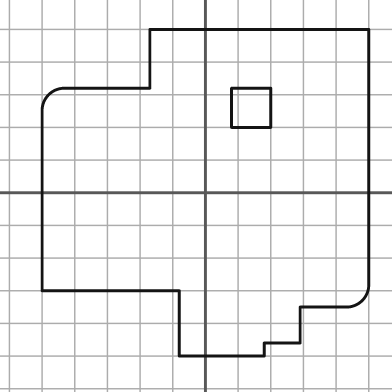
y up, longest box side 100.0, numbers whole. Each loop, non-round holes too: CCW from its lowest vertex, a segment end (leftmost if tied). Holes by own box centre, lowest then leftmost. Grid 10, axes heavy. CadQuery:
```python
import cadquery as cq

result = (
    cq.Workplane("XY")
    .moveTo(-8.0, -50.0)
    .lineTo(18.0, -50.0)
    .lineTo(18.0, -46.0)
    .lineTo(29.0, -46.0)
    .lineTo(29.0, -35.0)
    .lineTo(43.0, -35.0)
    .threePointArc((48.0, -33.0), (50.0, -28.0))
    .lineTo(50.0, 50.0)
    .lineTo(-17.0, 50.0)
    .lineTo(-17.0, 32.0)
    .lineTo(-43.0, 32.0)
    .threePointArc((-48.0, 30.0), (-50.0, 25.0))
    .lineTo(-50.0, -30.0)
    .lineTo(-8.0, -30.0)
    .close()
    .moveTo(8.0, 20.0)
    .lineTo(20.0, 20.0)
    .lineTo(20.0, 32.0)
    .lineTo(8.0, 32.0)
    .close()
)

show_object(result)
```